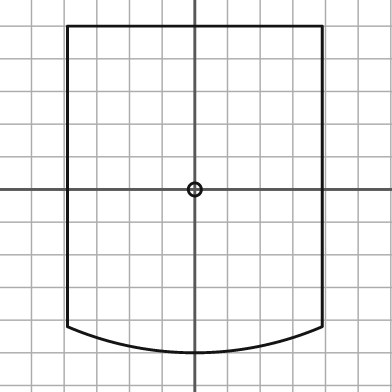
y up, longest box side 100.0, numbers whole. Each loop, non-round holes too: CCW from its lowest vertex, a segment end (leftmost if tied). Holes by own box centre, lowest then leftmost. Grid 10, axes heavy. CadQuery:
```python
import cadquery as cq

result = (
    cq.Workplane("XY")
    .moveTo(-39.0, -42.0)
    .threePointArc((0.0, -50.0), (39.0, -42.0))
    .lineTo(39.0, 50.0)
    .lineTo(-39.0, 50.0)
    .close()
    .moveTo(0.0, 0.0)
    .circle(2.0)
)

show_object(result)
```